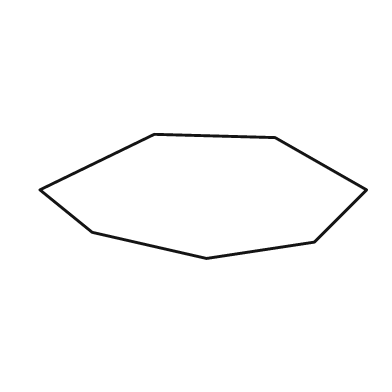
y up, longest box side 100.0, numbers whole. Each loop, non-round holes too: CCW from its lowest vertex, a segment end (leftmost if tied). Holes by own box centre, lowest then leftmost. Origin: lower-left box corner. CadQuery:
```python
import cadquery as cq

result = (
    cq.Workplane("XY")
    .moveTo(51.0, 0.0)
    .lineTo(84.0, 5.0)
    .lineTo(100.0, 21.0)
    .lineTo(72.0, 37.0)
    .lineTo(35.0, 38.0)
    .lineTo(0.0, 21.0)
    .lineTo(16.0, 8.0)
    .close()
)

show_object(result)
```